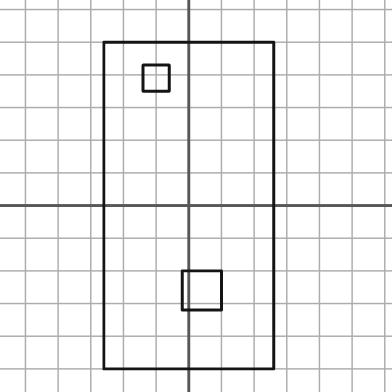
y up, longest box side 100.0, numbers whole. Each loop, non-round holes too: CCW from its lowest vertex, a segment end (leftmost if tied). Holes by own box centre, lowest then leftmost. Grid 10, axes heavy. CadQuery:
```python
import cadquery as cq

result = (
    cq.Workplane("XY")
    .moveTo(-26.0, -50.0)
    .lineTo(26.0, -50.0)
    .lineTo(26.0, 50.0)
    .lineTo(-26.0, 50.0)
    .close()
    .moveTo(-2.0, -32.0)
    .lineTo(10.0, -32.0)
    .lineTo(10.0, -20.0)
    .lineTo(-2.0, -20.0)
    .close()
    .moveTo(-14.0, 35.0)
    .lineTo(-6.0, 35.0)
    .lineTo(-6.0, 43.0)
    .lineTo(-14.0, 43.0)
    .close()
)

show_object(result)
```